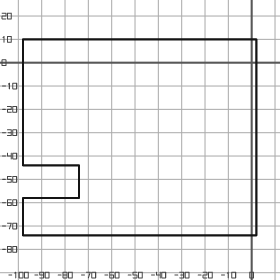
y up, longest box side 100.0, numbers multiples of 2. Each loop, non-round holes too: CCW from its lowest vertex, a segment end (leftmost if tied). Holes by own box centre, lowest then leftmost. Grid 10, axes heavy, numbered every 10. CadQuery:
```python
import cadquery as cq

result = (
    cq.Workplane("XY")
    .moveTo(-98.0, -74.0)
    .lineTo(2.0, -74.0)
    .lineTo(2.0, 10.0)
    .lineTo(-98.0, 10.0)
    .lineTo(-98.0, -44.0)
    .lineTo(-74.0, -44.0)
    .lineTo(-74.0, -58.0)
    .lineTo(-98.0, -58.0)
    .close()
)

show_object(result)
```